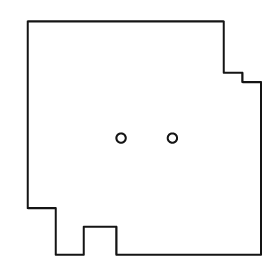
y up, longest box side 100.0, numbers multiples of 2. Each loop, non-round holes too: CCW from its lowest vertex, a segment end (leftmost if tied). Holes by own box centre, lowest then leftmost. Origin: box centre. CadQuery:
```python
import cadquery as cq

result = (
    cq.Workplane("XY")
    .moveTo(-38.0, -50.0)
    .lineTo(-26.0, -50.0)
    .lineTo(-26.0, -38.0)
    .lineTo(-12.0, -38.0)
    .lineTo(-12.0, -50.0)
    .lineTo(50.0, -50.0)
    .lineTo(50.0, 24.0)
    .lineTo(42.0, 24.0)
    .lineTo(42.0, 28.0)
    .lineTo(34.0, 28.0)
    .lineTo(34.0, 50.0)
    .lineTo(-50.0, 50.0)
    .lineTo(-50.0, -30.0)
    .lineTo(-38.0, -30.0)
    .close()
    .moveTo(-10.0, 0.0)
    .circle(2.0)
    .moveTo(12.0, 0.0)
    .circle(2.0)
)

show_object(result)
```